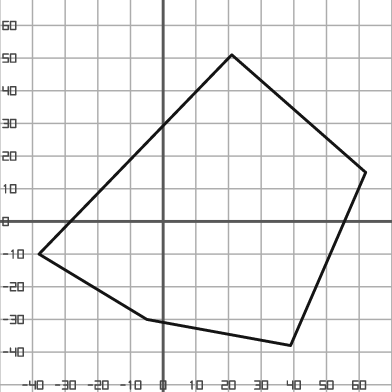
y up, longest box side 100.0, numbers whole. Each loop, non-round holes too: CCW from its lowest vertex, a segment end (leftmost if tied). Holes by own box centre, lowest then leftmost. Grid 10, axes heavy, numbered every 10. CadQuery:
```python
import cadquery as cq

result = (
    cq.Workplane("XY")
    .moveTo(39.0, -38.0)
    .lineTo(62.0, 15.0)
    .lineTo(21.0, 51.0)
    .lineTo(-38.0, -10.0)
    .lineTo(-5.0, -30.0)
    .close()
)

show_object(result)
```